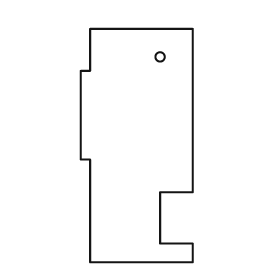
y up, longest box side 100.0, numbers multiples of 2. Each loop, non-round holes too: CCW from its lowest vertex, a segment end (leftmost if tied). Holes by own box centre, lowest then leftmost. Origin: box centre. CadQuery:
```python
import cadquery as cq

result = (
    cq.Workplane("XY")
    .moveTo(-20.0, -50.0)
    .lineTo(24.0, -50.0)
    .lineTo(24.0, -42.0)
    .lineTo(10.0, -42.0)
    .lineTo(10.0, -20.0)
    .lineTo(24.0, -20.0)
    .lineTo(24.0, 50.0)
    .lineTo(-20.0, 50.0)
    .lineTo(-20.0, 32.0)
    .lineTo(-24.0, 32.0)
    .lineTo(-24.0, -6.0)
    .lineTo(-20.0, -6.0)
    .close()
    .moveTo(10.0, 38.0)
    .circle(2.0)
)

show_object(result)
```